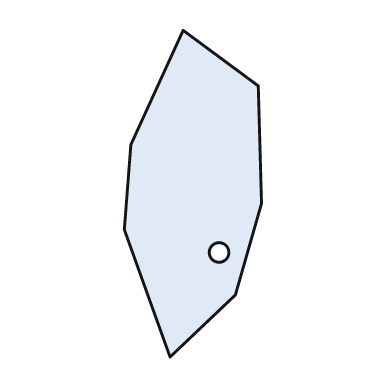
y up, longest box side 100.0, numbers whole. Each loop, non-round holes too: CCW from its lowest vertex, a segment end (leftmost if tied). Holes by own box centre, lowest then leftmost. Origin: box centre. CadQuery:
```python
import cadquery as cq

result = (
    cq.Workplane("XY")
    .moveTo(-7.0, -50.0)
    .lineTo(13.0, -31.0)
    .lineTo(21.0, -3.0)
    .lineTo(20.0, 33.0)
    .lineTo(-3.0, 50.0)
    .lineTo(-19.0, 15.0)
    .lineTo(-21.0, -11.0)
    .close()
    .moveTo(8.0, -18.0)
    .circle(3.0)
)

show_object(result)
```